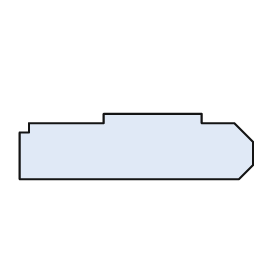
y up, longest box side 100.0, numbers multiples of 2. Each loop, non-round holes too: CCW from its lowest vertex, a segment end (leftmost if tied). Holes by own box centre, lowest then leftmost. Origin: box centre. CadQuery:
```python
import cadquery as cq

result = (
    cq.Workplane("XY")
    .moveTo(-50.0, -14.0)
    .lineTo(44.0, -14.0)
    .lineTo(50.0, -8.0)
    .lineTo(50.0, 2.0)
    .lineTo(42.0, 10.0)
    .lineTo(28.0, 10.0)
    .lineTo(28.0, 14.0)
    .lineTo(-14.0, 14.0)
    .lineTo(-14.0, 10.0)
    .lineTo(-46.0, 10.0)
    .lineTo(-46.0, 6.0)
    .lineTo(-50.0, 6.0)
    .close()
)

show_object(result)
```